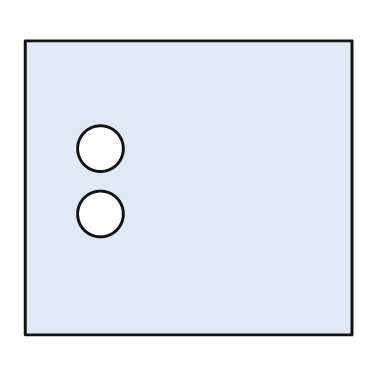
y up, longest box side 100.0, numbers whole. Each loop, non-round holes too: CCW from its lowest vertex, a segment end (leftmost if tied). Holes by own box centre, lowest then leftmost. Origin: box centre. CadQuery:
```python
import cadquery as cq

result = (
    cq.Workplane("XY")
    .moveTo(-50.0, -45.0)
    .lineTo(50.0, -45.0)
    .lineTo(50.0, 45.0)
    .lineTo(-50.0, 45.0)
    .close()
    .moveTo(-27.0, -8.0)
    .circle(7.0)
    .moveTo(-27.0, 12.0)
    .circle(7.0)
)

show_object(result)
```